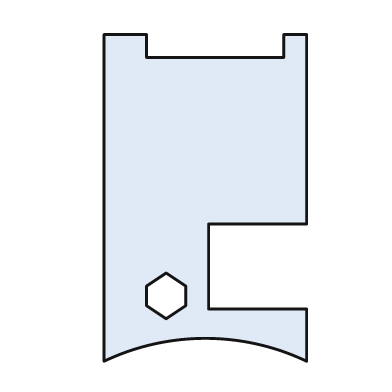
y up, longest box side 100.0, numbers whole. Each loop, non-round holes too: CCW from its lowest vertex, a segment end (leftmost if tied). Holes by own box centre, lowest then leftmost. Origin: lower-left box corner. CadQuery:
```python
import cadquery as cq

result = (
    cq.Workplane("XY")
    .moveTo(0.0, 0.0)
    .threePointArc((31.0, 7.0), (62.0, 0.0))
    .lineTo(62.0, 16.0)
    .lineTo(32.0, 16.0)
    .lineTo(32.0, 42.0)
    .lineTo(62.0, 42.0)
    .lineTo(62.0, 100.0)
    .lineTo(55.0, 100.0)
    .lineTo(55.0, 93.0)
    .lineTo(13.0, 93.0)
    .lineTo(13.0, 100.0)
    .lineTo(0.0, 100.0)
    .close()
    .moveTo(19.0, 13.0)
    .lineTo(25.0, 17.0)
    .lineTo(25.0, 23.0)
    .lineTo(19.0, 27.0)
    .lineTo(13.0, 23.0)
    .lineTo(13.0, 17.0)
    .close()
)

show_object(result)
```